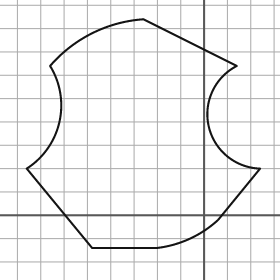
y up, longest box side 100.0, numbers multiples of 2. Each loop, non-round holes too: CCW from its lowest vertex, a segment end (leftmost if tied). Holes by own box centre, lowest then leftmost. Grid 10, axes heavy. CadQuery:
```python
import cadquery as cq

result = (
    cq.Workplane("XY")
    .moveTo(-48.0, -14.0)
    .lineTo(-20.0, -14.0)
    .threePointArc((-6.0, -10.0), (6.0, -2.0))
    .lineTo(24.0, 20.0)
    .threePointArc((2.0, 38.0), (14.0, 64.0))
    .lineTo(-26.0, 84.0)
    .threePointArc((-48.0, 78.0), (-66.0, 64.0))
    .threePointArc((-62.0, 40.0), (-76.0, 20.0))
    .close()
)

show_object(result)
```